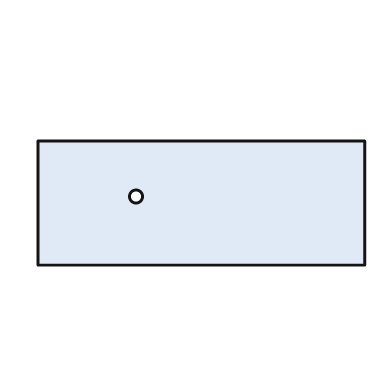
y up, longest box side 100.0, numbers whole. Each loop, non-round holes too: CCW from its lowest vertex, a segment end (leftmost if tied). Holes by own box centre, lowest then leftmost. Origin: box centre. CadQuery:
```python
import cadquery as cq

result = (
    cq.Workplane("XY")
    .moveTo(-50.0, -19.0)
    .lineTo(50.0, -19.0)
    .lineTo(50.0, 19.0)
    .lineTo(-50.0, 19.0)
    .close()
    .moveTo(-20.0, 2.0)
    .circle(2.0)
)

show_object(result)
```